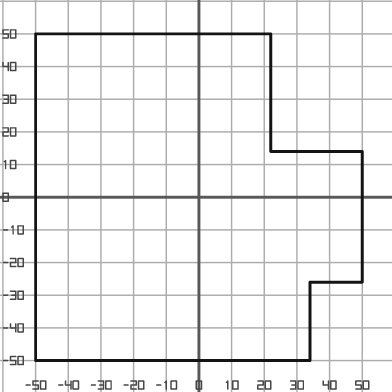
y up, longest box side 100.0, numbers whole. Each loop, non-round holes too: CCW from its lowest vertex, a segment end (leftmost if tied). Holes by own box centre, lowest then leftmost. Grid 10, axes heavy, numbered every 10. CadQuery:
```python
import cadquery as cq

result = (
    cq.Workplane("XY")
    .moveTo(-50.0, -50.0)
    .lineTo(34.0, -50.0)
    .lineTo(34.0, -26.0)
    .lineTo(50.0, -26.0)
    .lineTo(50.0, 14.0)
    .lineTo(22.0, 14.0)
    .lineTo(22.0, 50.0)
    .lineTo(-50.0, 50.0)
    .close()
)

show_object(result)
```